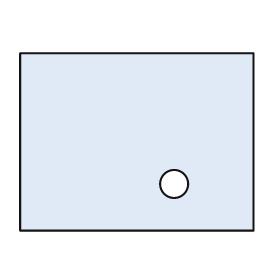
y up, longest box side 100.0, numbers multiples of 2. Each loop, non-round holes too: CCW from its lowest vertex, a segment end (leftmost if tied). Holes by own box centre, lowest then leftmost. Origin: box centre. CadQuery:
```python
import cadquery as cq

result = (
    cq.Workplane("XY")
    .moveTo(-50.0, -38.0)
    .lineTo(50.0, -38.0)
    .lineTo(50.0, 38.0)
    .lineTo(-50.0, 38.0)
    .close()
    .moveTo(16.0, -18.0)
    .circle(6.0)
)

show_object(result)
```